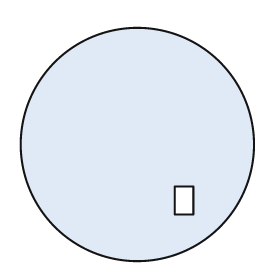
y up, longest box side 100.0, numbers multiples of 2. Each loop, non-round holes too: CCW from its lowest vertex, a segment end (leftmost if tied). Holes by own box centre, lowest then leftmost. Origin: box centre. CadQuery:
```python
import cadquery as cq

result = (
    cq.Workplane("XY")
    .moveTo(0.0, 0.0)
    .circle(50.0)
    .moveTo(16.0, -30.0)
    .lineTo(24.0, -30.0)
    .lineTo(24.0, -18.0)
    .lineTo(16.0, -18.0)
    .close()
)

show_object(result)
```